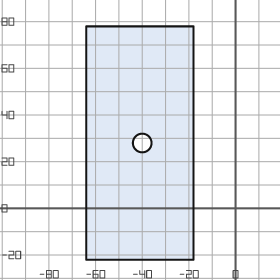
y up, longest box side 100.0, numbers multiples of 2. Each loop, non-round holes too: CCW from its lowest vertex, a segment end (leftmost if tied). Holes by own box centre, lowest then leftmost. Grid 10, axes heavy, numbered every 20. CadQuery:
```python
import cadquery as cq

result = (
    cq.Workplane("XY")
    .moveTo(-64.0, -22.0)
    .lineTo(-18.0, -22.0)
    .lineTo(-18.0, 78.0)
    .lineTo(-64.0, 78.0)
    .close()
    .moveTo(-40.0, 28.0)
    .circle(4.0)
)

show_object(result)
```